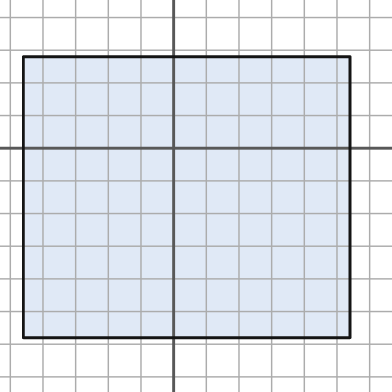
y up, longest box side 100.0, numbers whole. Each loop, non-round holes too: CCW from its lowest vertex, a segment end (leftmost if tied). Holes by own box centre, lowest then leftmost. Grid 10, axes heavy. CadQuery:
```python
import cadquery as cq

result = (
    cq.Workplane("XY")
    .moveTo(-46.0, -58.0)
    .lineTo(54.0, -58.0)
    .lineTo(54.0, 28.0)
    .lineTo(-46.0, 28.0)
    .close()
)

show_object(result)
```